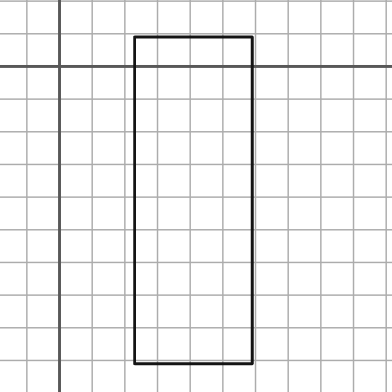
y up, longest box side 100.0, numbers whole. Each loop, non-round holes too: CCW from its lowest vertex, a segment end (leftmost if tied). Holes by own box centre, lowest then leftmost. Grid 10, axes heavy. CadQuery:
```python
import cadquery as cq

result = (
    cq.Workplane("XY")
    .moveTo(23.0, -91.0)
    .lineTo(59.0, -91.0)
    .lineTo(59.0, 9.0)
    .lineTo(23.0, 9.0)
    .close()
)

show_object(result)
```